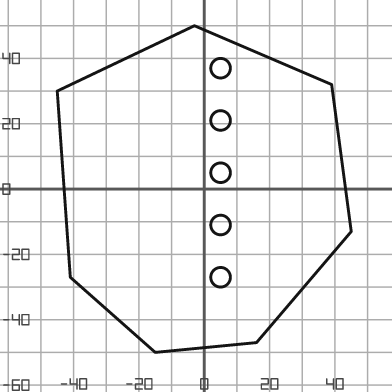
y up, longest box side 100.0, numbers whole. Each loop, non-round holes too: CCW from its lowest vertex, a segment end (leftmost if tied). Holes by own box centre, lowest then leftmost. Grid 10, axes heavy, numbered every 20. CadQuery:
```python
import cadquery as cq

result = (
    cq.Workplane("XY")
    .moveTo(-15.0, -50.0)
    .lineTo(16.0, -47.0)
    .lineTo(45.0, -13.0)
    .lineTo(39.0, 32.0)
    .lineTo(-3.0, 50.0)
    .lineTo(-45.0, 30.0)
    .lineTo(-41.0, -27.0)
    .close()
    .moveTo(5.0, -27.0)
    .circle(3.0)
    .moveTo(5.0, -11.0)
    .circle(3.0)
    .moveTo(5.0, 5.0)
    .circle(3.0)
    .moveTo(5.0, 21.0)
    .circle(3.0)
    .moveTo(5.0, 37.0)
    .circle(3.0)
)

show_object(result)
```